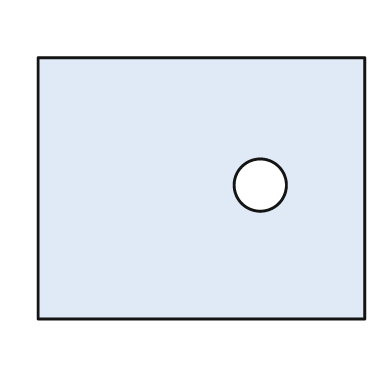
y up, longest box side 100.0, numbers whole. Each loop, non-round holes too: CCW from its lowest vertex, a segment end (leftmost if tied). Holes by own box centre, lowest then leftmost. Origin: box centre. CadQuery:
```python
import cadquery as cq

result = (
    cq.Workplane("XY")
    .moveTo(-50.0, -40.0)
    .lineTo(50.0, -40.0)
    .lineTo(50.0, 40.0)
    .lineTo(-50.0, 40.0)
    .close()
    .moveTo(18.0, 1.0)
    .circle(8.0)
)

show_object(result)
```